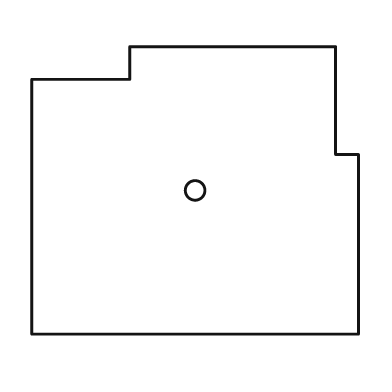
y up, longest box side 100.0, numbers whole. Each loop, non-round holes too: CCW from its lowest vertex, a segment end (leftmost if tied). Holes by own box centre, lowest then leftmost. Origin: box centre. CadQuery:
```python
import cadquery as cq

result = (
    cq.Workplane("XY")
    .moveTo(-50.0, -44.0)
    .lineTo(50.0, -44.0)
    .lineTo(50.0, 11.0)
    .lineTo(43.0, 11.0)
    .lineTo(43.0, 44.0)
    .lineTo(-20.0, 44.0)
    .lineTo(-20.0, 34.0)
    .lineTo(-50.0, 34.0)
    .close()
    .moveTo(0.0, 0.0)
    .circle(3.0)
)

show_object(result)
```